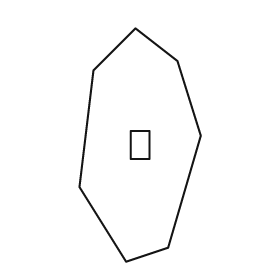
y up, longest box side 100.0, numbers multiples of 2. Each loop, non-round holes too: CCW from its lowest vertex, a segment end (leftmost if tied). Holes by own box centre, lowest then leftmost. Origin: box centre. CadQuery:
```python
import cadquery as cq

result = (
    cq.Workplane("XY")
    .moveTo(-6.0, -50.0)
    .lineTo(12.0, -44.0)
    .lineTo(26.0, 4.0)
    .lineTo(16.0, 36.0)
    .lineTo(-2.0, 50.0)
    .lineTo(-20.0, 32.0)
    .lineTo(-26.0, -18.0)
    .close()
    .moveTo(-4.0, -6.0)
    .lineTo(4.0, -6.0)
    .lineTo(4.0, 6.0)
    .lineTo(-4.0, 6.0)
    .close()
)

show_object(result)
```